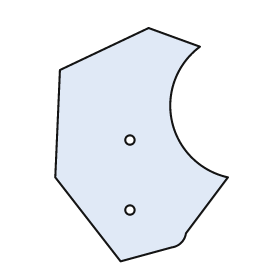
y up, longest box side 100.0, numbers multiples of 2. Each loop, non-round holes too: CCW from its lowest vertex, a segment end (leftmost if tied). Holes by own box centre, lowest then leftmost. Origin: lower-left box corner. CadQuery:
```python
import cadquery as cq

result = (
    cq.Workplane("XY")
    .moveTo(28.0, 0.0)
    .lineTo(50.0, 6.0)
    .threePointArc((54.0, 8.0), (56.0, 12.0))
    .lineTo(74.0, 36.0)
    .threePointArc((50.0, 60.0), (62.0, 92.0))
    .lineTo(40.0, 100.0)
    .lineTo(2.0, 82.0)
    .lineTo(0.0, 36.0)
    .close()
    .moveTo(32.0, 22.0)
    .circle(2.0)
    .moveTo(32.0, 52.0)
    .circle(2.0)
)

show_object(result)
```